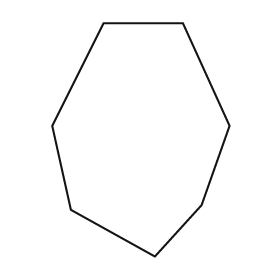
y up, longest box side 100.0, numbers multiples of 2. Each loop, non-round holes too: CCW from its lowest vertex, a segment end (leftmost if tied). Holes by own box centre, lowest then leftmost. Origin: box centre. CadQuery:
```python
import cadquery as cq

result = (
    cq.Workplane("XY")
    .moveTo(6.0, -50.0)
    .lineTo(26.0, -28.0)
    .lineTo(38.0, 6.0)
    .lineTo(18.0, 50.0)
    .lineTo(-16.0, 50.0)
    .lineTo(-38.0, 6.0)
    .lineTo(-30.0, -30.0)
    .close()
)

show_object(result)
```